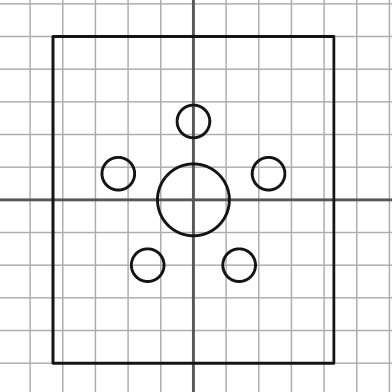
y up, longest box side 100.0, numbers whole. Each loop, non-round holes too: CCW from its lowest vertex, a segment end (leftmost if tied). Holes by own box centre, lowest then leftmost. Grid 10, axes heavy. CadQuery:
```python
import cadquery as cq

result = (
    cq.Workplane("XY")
    .moveTo(-43.0, -50.0)
    .lineTo(43.0, -50.0)
    .lineTo(43.0, 50.0)
    .lineTo(-43.0, 50.0)
    .close()
    .moveTo(-14.0, -20.0)
    .circle(5.0)
    .moveTo(14.0, -20.0)
    .circle(5.0)
    .moveTo(0.0, 0.0)
    .circle(11.0)
    .moveTo(-23.0, 8.0)
    .circle(5.0)
    .moveTo(23.0, 8.0)
    .circle(5.0)
    .moveTo(0.0, 24.0)
    .circle(5.0)
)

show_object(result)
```